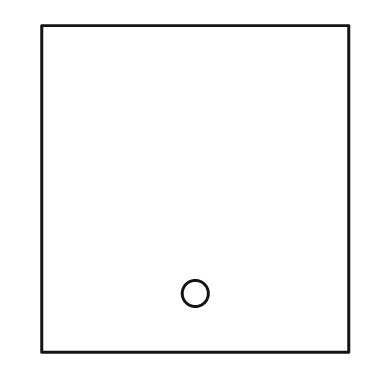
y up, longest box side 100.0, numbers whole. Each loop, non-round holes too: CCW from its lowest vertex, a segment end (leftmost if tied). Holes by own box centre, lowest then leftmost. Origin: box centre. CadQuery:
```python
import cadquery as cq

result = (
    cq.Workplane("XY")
    .moveTo(-47.0, -50.0)
    .lineTo(47.0, -50.0)
    .lineTo(47.0, 50.0)
    .lineTo(-47.0, 50.0)
    .close()
    .moveTo(0.0, -32.0)
    .circle(4.0)
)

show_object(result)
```